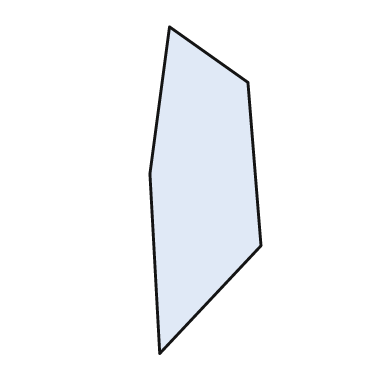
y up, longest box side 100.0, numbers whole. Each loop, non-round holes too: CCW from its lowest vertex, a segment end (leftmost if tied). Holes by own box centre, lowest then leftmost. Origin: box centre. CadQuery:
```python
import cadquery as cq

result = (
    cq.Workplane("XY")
    .moveTo(-14.0, -50.0)
    .lineTo(17.0, -17.0)
    .lineTo(13.0, 33.0)
    .lineTo(-11.0, 50.0)
    .lineTo(-17.0, 5.0)
    .close()
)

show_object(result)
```